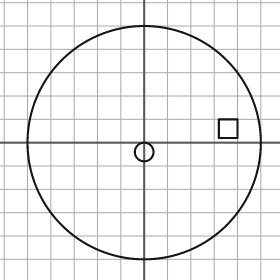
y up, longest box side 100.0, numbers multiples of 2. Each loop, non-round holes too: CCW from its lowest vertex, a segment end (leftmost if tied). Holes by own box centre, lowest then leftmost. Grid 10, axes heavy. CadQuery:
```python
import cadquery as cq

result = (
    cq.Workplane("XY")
    .moveTo(0.0, 0.0)
    .circle(50.0)
    .moveTo(0.0, -4.0)
    .circle(4.0)
    .moveTo(32.0, 2.0)
    .lineTo(40.0, 2.0)
    .lineTo(40.0, 10.0)
    .lineTo(32.0, 10.0)
    .close()
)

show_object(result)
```